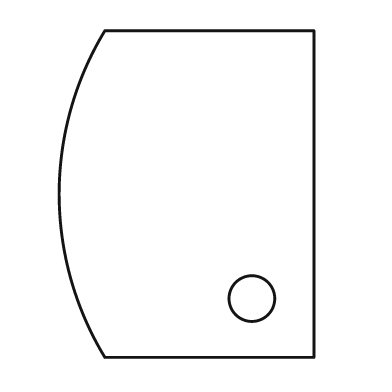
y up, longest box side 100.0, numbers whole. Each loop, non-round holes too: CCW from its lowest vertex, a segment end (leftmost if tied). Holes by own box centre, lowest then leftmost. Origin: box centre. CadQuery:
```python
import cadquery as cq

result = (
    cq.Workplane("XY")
    .moveTo(-25.0, -50.0)
    .lineTo(39.0, -50.0)
    .lineTo(39.0, 50.0)
    .lineTo(-25.0, 50.0)
    .threePointArc((-39.0, 0.0), (-25.0, -50.0))
    .close()
    .moveTo(20.0, -32.0)
    .circle(7.0)
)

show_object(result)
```